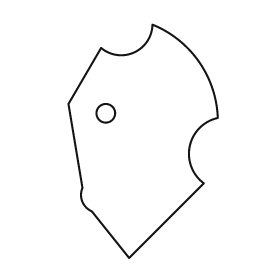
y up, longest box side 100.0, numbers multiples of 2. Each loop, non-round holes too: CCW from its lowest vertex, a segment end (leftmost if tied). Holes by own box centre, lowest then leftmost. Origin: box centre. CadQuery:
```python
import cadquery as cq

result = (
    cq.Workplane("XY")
    .moveTo(-6.0, -50.0)
    .lineTo(26.0, -18.0)
    .threePointArc((20.0, -2.0), (32.0, 10.0))
    .threePointArc((24.0, 34.0), (4.0, 50.0))
    .threePointArc((-4.0, 38.0), (-18.0, 40.0))
    .lineTo(-32.0, 16.0)
    .lineTo(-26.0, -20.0)
    .threePointArc((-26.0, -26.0), (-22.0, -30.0))
    .close()
    .moveTo(-16.0, 12.0)
    .circle(4.0)
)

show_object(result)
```